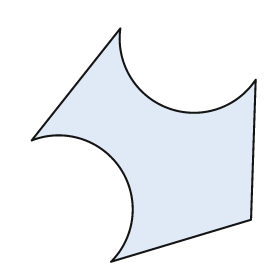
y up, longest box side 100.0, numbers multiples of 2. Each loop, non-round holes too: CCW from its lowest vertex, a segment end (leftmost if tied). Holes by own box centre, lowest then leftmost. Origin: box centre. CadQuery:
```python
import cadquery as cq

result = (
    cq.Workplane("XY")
    .moveTo(-14.0, -50.0)
    .lineTo(46.0, -32.0)
    .lineTo(48.0, 28.0)
    .threePointArc((10.0, 16.0), (-10.0, 50.0))
    .lineTo(-48.0, 2.0)
    .threePointArc((-10.0, -10.0), (-14.0, -50.0))
    .close()
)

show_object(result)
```